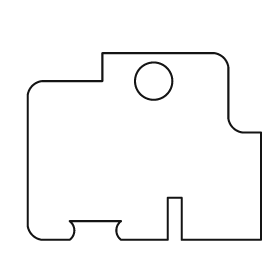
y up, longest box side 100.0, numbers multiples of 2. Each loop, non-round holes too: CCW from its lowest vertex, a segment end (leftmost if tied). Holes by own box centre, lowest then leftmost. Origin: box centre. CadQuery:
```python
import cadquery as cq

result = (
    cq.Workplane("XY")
    .moveTo(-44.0, -40.0)
    .lineTo(-32.0, -40.0)
    .threePointArc((-30.0, -36.0), (-32.0, -32.0))
    .lineTo(-10.0, -32.0)
    .threePointArc((-12.0, -36.0), (-10.0, -40.0))
    .lineTo(10.0, -40.0)
    .lineTo(10.0, -22.0)
    .lineTo(16.0, -22.0)
    .lineTo(16.0, -40.0)
    .lineTo(50.0, -40.0)
    .lineTo(50.0, 6.0)
    .lineTo(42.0, 6.0)
    .threePointArc((38.0, 8.0), (36.0, 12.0))
    .lineTo(36.0, 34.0)
    .threePointArc((34.0, 38.0), (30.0, 40.0))
    .lineTo(-18.0, 40.0)
    .lineTo(-18.0, 28.0)
    .lineTo(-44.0, 28.0)
    .threePointArc((-48.0, 26.0), (-50.0, 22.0))
    .lineTo(-50.0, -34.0)
    .threePointArc((-48.0, -38.0), (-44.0, -40.0))
    .close()
    .moveTo(4.0, 28.0)
    .circle(8.0)
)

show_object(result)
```